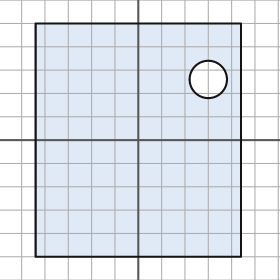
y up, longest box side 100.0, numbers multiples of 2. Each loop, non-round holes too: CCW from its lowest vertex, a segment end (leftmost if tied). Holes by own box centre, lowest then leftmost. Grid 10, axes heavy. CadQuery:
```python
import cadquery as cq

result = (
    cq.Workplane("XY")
    .moveTo(-44.0, -50.0)
    .lineTo(44.0, -50.0)
    .lineTo(44.0, 50.0)
    .lineTo(-44.0, 50.0)
    .close()
    .moveTo(30.0, 26.0)
    .circle(8.0)
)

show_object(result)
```